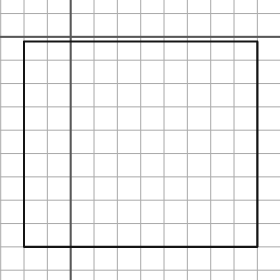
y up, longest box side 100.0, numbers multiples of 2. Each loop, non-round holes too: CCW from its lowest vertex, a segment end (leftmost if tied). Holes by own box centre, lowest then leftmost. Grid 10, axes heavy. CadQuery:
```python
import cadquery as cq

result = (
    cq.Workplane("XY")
    .moveTo(-20.0, -90.0)
    .lineTo(80.0, -90.0)
    .lineTo(80.0, -2.0)
    .lineTo(-20.0, -2.0)
    .close()
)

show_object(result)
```